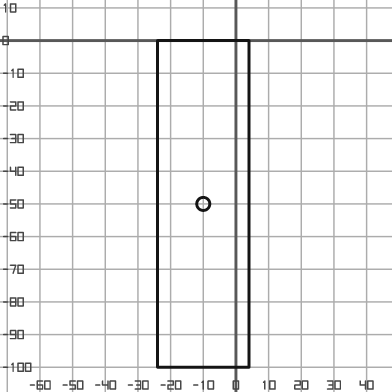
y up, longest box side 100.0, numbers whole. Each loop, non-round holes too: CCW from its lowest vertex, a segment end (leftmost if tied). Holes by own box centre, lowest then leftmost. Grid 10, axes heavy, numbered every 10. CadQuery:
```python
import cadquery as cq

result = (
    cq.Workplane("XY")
    .moveTo(-24.0, -100.0)
    .lineTo(4.0, -100.0)
    .lineTo(4.0, 0.0)
    .lineTo(-24.0, 0.0)
    .close()
    .moveTo(-10.0, -50.0)
    .circle(2.0)
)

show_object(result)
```